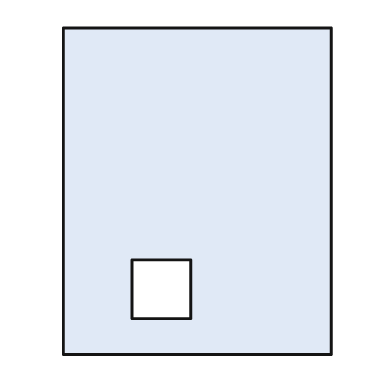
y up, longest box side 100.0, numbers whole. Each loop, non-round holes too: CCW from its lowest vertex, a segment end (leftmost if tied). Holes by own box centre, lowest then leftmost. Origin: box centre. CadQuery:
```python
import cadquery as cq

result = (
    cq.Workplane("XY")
    .moveTo(-41.0, -50.0)
    .lineTo(41.0, -50.0)
    .lineTo(41.0, 50.0)
    .lineTo(-41.0, 50.0)
    .close()
    .moveTo(-20.0, -39.0)
    .lineTo(-2.0, -39.0)
    .lineTo(-2.0, -21.0)
    .lineTo(-20.0, -21.0)
    .close()
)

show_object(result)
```